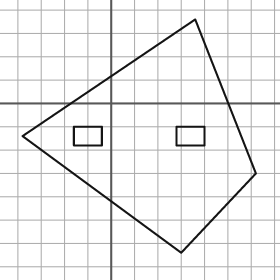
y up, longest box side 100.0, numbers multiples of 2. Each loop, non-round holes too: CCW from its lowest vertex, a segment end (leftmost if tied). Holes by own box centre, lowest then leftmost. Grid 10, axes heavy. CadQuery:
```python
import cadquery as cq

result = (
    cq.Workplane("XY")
    .moveTo(30.0, -64.0)
    .lineTo(62.0, -30.0)
    .lineTo(36.0, 36.0)
    .lineTo(-38.0, -14.0)
    .close()
    .moveTo(-16.0, -18.0)
    .lineTo(-4.0, -18.0)
    .lineTo(-4.0, -10.0)
    .lineTo(-16.0, -10.0)
    .close()
    .moveTo(28.0, -18.0)
    .lineTo(40.0, -18.0)
    .lineTo(40.0, -10.0)
    .lineTo(28.0, -10.0)
    .close()
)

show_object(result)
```